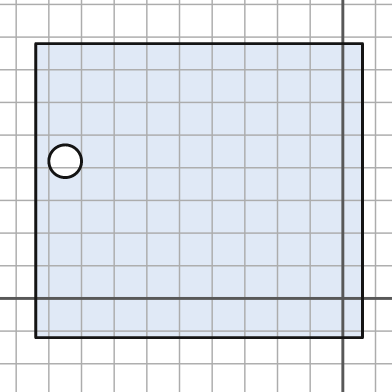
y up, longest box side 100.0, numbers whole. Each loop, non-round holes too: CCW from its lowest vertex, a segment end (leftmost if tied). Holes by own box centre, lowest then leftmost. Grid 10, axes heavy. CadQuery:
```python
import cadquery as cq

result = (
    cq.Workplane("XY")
    .moveTo(-94.0, -12.0)
    .lineTo(6.0, -12.0)
    .lineTo(6.0, 78.0)
    .lineTo(-94.0, 78.0)
    .close()
    .moveTo(-85.0, 42.0)
    .circle(5.0)
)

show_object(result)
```